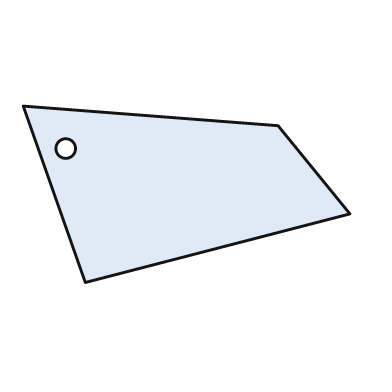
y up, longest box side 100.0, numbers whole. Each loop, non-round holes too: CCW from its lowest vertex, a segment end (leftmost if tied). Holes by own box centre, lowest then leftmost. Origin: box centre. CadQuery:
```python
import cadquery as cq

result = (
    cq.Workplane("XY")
    .moveTo(-31.0, -27.0)
    .lineTo(50.0, -6.0)
    .lineTo(28.0, 21.0)
    .lineTo(-50.0, 27.0)
    .close()
    .moveTo(-37.0, 14.0)
    .circle(3.0)
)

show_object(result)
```